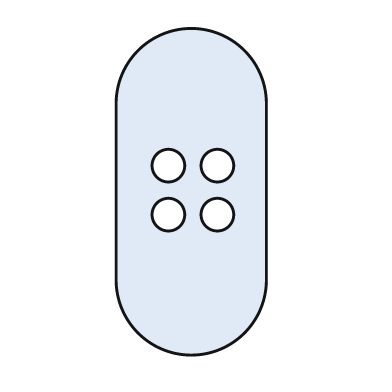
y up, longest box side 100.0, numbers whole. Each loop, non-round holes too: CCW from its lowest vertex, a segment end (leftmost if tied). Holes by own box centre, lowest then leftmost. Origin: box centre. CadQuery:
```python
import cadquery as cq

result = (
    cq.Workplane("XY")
    .moveTo(-23.0, -27.0)
    .threePointArc((0.0, -50.0), (23.0, -27.0))
    .lineTo(23.0, 27.0)
    .threePointArc((0.0, 50.0), (-23.0, 27.0))
    .close()
    .moveTo(-7.0, -7.0)
    .circle(5.0)
    .moveTo(8.0, -7.0)
    .circle(5.0)
    .moveTo(-7.0, 8.0)
    .circle(5.0)
    .moveTo(8.0, 8.0)
    .circle(5.0)
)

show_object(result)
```